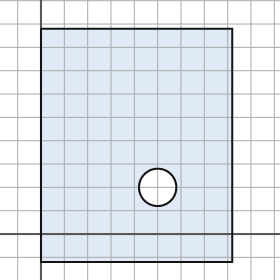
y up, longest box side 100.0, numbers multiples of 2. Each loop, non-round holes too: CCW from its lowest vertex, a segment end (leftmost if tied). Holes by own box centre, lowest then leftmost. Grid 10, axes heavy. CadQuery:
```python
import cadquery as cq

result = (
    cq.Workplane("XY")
    .moveTo(0.0, -12.0)
    .lineTo(82.0, -12.0)
    .lineTo(82.0, 88.0)
    .lineTo(0.0, 88.0)
    .close()
    .moveTo(50.0, 20.0)
    .circle(8.0)
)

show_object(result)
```